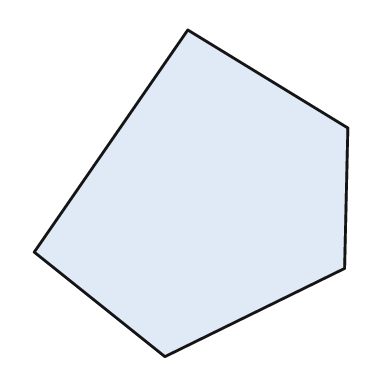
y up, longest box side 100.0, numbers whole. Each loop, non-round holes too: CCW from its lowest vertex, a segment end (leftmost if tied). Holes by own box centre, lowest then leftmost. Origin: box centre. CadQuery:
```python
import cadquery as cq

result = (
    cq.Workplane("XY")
    .moveTo(-8.0, -50.0)
    .lineTo(47.0, -23.0)
    .lineTo(48.0, 20.0)
    .lineTo(-1.0, 50.0)
    .lineTo(-48.0, -18.0)
    .close()
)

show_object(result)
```